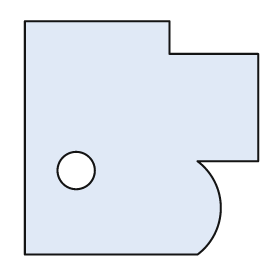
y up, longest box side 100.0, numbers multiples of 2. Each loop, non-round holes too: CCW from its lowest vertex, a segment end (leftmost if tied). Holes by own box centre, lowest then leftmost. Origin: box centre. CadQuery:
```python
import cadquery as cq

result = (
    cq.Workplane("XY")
    .moveTo(-50.0, -50.0)
    .lineTo(24.0, -50.0)
    .threePointArc((34.0, -30.0), (24.0, -10.0))
    .lineTo(50.0, -10.0)
    .lineTo(50.0, 36.0)
    .lineTo(12.0, 36.0)
    .lineTo(12.0, 50.0)
    .lineTo(-50.0, 50.0)
    .close()
    .moveTo(-28.0, -14.0)
    .circle(8.0)
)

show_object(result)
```